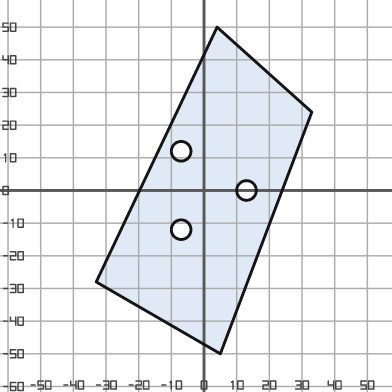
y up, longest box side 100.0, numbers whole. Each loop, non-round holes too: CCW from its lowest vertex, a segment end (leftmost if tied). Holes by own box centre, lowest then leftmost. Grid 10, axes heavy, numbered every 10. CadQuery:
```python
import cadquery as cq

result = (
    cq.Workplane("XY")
    .moveTo(5.0, -50.0)
    .lineTo(33.0, 24.0)
    .lineTo(4.0, 50.0)
    .lineTo(-33.0, -28.0)
    .close()
    .moveTo(-7.0, -12.0)
    .circle(3.0)
    .moveTo(13.0, 0.0)
    .circle(3.0)
    .moveTo(-7.0, 12.0)
    .circle(3.0)
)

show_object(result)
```